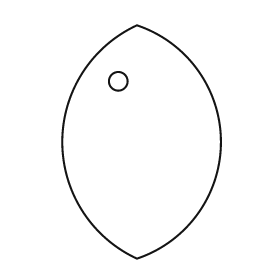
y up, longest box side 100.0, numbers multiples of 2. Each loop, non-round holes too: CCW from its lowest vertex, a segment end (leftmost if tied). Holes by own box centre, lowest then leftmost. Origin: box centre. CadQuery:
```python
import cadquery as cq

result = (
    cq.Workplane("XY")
    .moveTo(-2.0, -50.0)
    .threePointArc((34.0, 0.0), (-2.0, 50.0))
    .threePointArc((-34.0, 0.0), (-2.0, -50.0))
    .close()
    .moveTo(-10.0, 26.0)
    .circle(4.0)
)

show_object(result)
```